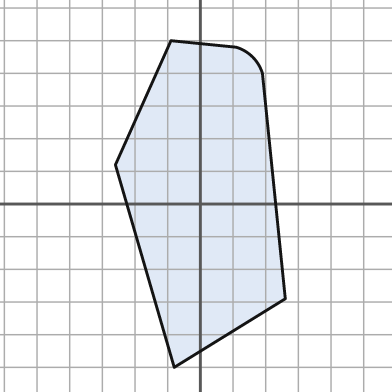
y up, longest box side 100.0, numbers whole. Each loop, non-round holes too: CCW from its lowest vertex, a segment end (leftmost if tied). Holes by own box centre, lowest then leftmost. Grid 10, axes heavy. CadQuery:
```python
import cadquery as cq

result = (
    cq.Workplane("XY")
    .moveTo(-8.0, -50.0)
    .lineTo(26.0, -29.0)
    .lineTo(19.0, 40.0)
    .threePointArc((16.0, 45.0), (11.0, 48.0))
    .lineTo(-9.0, 50.0)
    .lineTo(-26.0, 12.0)
    .close()
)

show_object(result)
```